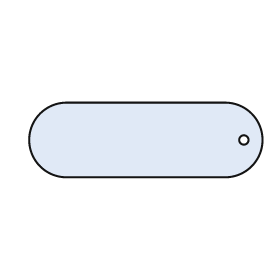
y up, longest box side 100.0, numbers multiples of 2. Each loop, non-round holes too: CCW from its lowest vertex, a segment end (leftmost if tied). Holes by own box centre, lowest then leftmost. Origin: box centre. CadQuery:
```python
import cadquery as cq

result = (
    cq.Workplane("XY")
    .moveTo(-34.0, -16.0)
    .lineTo(34.0, -16.0)
    .threePointArc((50.0, 0.0), (34.0, 16.0))
    .lineTo(-34.0, 16.0)
    .threePointArc((-50.0, 0.0), (-34.0, -16.0))
    .close()
    .moveTo(42.0, 0.0)
    .circle(2.0)
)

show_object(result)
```